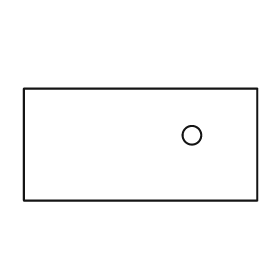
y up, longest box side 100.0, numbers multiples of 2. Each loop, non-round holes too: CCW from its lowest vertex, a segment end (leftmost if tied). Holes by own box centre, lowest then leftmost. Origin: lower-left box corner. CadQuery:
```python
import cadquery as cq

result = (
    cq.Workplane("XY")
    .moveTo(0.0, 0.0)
    .lineTo(100.0, 0.0)
    .lineTo(100.0, 48.0)
    .lineTo(0.0, 48.0)
    .close()
    .moveTo(72.0, 28.0)
    .circle(4.0)
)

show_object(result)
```